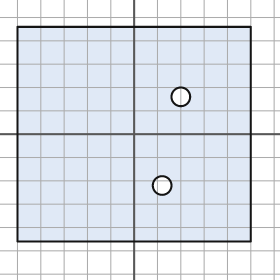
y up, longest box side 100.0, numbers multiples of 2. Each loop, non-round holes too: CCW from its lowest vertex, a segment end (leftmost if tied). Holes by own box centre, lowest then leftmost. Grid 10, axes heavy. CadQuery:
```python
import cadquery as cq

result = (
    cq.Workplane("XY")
    .moveTo(-50.0, -46.0)
    .lineTo(50.0, -46.0)
    .lineTo(50.0, 46.0)
    .lineTo(-50.0, 46.0)
    .close()
    .moveTo(12.0, -22.0)
    .circle(4.0)
    .moveTo(20.0, 16.0)
    .circle(4.0)
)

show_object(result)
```